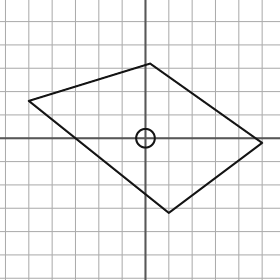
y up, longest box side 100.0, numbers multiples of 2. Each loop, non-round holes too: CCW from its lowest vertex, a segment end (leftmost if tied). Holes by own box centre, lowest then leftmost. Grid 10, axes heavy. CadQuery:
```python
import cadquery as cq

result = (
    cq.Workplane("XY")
    .moveTo(10.0, -32.0)
    .lineTo(50.0, -2.0)
    .lineTo(2.0, 32.0)
    .lineTo(-50.0, 16.0)
    .close()
    .moveTo(0.0, 0.0)
    .circle(4.0)
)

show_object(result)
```